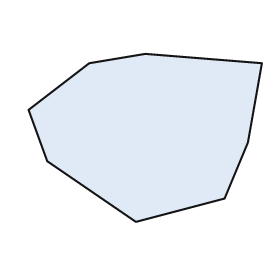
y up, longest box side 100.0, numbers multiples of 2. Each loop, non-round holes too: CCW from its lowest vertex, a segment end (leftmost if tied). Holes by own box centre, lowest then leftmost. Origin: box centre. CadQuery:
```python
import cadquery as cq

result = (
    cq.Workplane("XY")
    .moveTo(-4.0, -36.0)
    .lineTo(34.0, -26.0)
    .lineTo(44.0, -2.0)
    .lineTo(50.0, 32.0)
    .lineTo(0.0, 36.0)
    .lineTo(-24.0, 32.0)
    .lineTo(-50.0, 12.0)
    .lineTo(-42.0, -10.0)
    .close()
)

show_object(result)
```